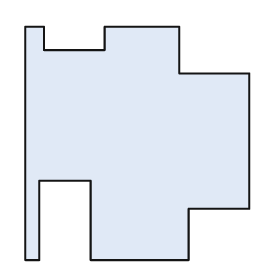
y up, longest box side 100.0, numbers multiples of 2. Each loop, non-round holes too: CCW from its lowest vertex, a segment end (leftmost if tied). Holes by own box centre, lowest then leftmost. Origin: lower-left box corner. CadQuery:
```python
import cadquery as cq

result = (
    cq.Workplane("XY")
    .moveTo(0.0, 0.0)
    .lineTo(6.0, 0.0)
    .lineTo(6.0, 34.0)
    .lineTo(28.0, 34.0)
    .lineTo(28.0, 0.0)
    .lineTo(70.0, 0.0)
    .lineTo(70.0, 22.0)
    .lineTo(96.0, 22.0)
    .lineTo(96.0, 80.0)
    .lineTo(66.0, 80.0)
    .lineTo(66.0, 100.0)
    .lineTo(34.0, 100.0)
    .lineTo(34.0, 90.0)
    .lineTo(8.0, 90.0)
    .lineTo(8.0, 100.0)
    .lineTo(0.0, 100.0)
    .close()
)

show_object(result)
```